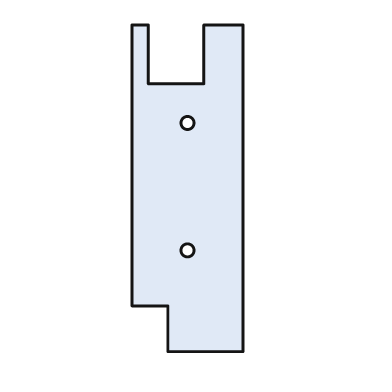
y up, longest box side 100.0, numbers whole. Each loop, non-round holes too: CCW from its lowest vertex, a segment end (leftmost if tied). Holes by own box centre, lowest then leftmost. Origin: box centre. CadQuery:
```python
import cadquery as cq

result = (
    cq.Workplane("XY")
    .moveTo(-6.0, -50.0)
    .lineTo(17.0, -50.0)
    .lineTo(17.0, 50.0)
    .lineTo(5.0, 50.0)
    .lineTo(5.0, 32.0)
    .lineTo(-12.0, 32.0)
    .lineTo(-12.0, 50.0)
    .lineTo(-17.0, 50.0)
    .lineTo(-17.0, -36.0)
    .lineTo(-6.0, -36.0)
    .close()
    .moveTo(0.0, -19.0)
    .circle(2.0)
    .moveTo(0.0, 20.0)
    .circle(2.0)
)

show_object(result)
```